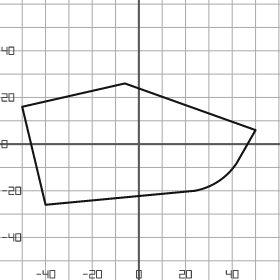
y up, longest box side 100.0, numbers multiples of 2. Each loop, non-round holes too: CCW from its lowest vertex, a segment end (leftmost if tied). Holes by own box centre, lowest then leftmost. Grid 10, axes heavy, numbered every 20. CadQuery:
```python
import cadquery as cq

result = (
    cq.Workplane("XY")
    .moveTo(-40.0, -26.0)
    .lineTo(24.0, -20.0)
    .threePointArc((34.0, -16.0), (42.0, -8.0))
    .lineTo(50.0, 6.0)
    .lineTo(-6.0, 26.0)
    .lineTo(-50.0, 16.0)
    .close()
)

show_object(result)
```